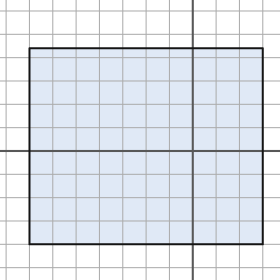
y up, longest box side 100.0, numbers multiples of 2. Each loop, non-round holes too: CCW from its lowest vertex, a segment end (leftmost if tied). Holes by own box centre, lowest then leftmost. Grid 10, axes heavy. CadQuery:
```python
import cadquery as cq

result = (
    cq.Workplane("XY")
    .moveTo(-70.0, -40.0)
    .lineTo(30.0, -40.0)
    .lineTo(30.0, 44.0)
    .lineTo(-70.0, 44.0)
    .close()
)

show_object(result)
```